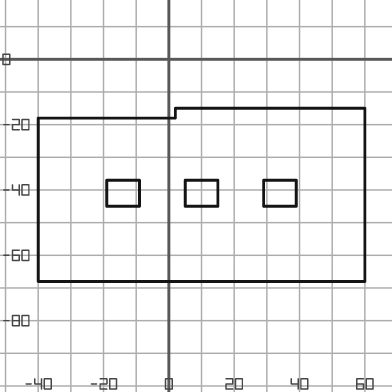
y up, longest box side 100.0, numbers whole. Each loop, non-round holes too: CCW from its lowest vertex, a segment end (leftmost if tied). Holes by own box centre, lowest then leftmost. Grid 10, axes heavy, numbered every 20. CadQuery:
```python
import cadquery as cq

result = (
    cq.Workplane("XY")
    .moveTo(-40.0, -68.0)
    .lineTo(60.0, -68.0)
    .lineTo(60.0, -15.0)
    .lineTo(2.0, -15.0)
    .lineTo(2.0, -18.0)
    .lineTo(-40.0, -18.0)
    .close()
    .moveTo(-19.0, -45.0)
    .lineTo(-9.0, -45.0)
    .lineTo(-9.0, -37.0)
    .lineTo(-19.0, -37.0)
    .close()
    .moveTo(5.0, -45.0)
    .lineTo(15.0, -45.0)
    .lineTo(15.0, -37.0)
    .lineTo(5.0, -37.0)
    .close()
    .moveTo(29.0, -45.0)
    .lineTo(39.0, -45.0)
    .lineTo(39.0, -37.0)
    .lineTo(29.0, -37.0)
    .close()
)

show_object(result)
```